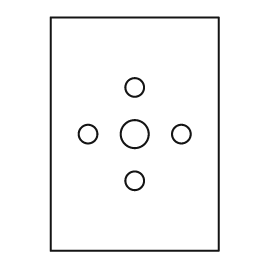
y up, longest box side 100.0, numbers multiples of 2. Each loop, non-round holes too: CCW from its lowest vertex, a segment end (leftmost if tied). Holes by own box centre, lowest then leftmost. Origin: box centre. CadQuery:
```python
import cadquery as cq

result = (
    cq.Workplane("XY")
    .moveTo(-36.0, -50.0)
    .lineTo(36.0, -50.0)
    .lineTo(36.0, 50.0)
    .lineTo(-36.0, 50.0)
    .close()
    .moveTo(0.0, -20.0)
    .circle(4.0)
    .moveTo(-20.0, 0.0)
    .circle(4.0)
    .moveTo(0.0, 0.0)
    .circle(6.0)
    .moveTo(20.0, 0.0)
    .circle(4.0)
    .moveTo(0.0, 20.0)
    .circle(4.0)
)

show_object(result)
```